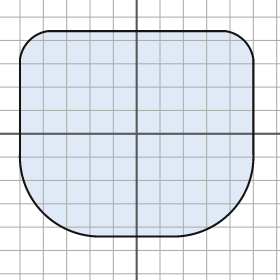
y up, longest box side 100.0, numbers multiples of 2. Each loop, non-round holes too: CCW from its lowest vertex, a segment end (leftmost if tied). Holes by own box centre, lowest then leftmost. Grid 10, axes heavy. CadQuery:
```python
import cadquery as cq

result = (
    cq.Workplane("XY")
    .moveTo(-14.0, -44.0)
    .lineTo(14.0, -44.0)
    .threePointArc((40.0, -34.0), (50.0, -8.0))
    .lineTo(50.0, 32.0)
    .threePointArc((46.0, 40.0), (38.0, 44.0))
    .lineTo(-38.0, 44.0)
    .threePointArc((-46.0, 40.0), (-50.0, 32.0))
    .lineTo(-50.0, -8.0)
    .threePointArc((-40.0, -34.0), (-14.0, -44.0))
    .close()
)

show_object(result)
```